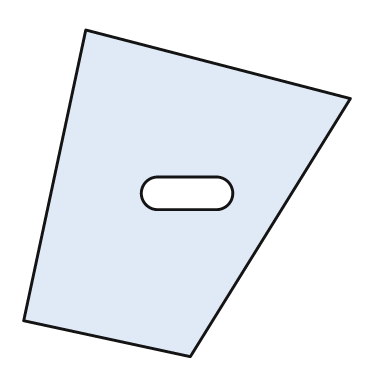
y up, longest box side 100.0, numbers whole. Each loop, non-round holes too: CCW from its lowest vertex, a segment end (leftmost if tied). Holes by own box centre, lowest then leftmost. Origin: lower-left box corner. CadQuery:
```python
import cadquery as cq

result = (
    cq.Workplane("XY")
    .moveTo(51.0, 0.0)
    .lineTo(100.0, 79.0)
    .lineTo(19.0, 100.0)
    .lineTo(0.0, 11.0)
    .close()
    .moveTo(41.0, 45.0)
    .lineTo(59.0, 45.0)
    .threePointArc((64.0, 50.0), (59.0, 55.0))
    .lineTo(41.0, 55.0)
    .threePointArc((36.0, 50.0), (41.0, 45.0))
    .close()
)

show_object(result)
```